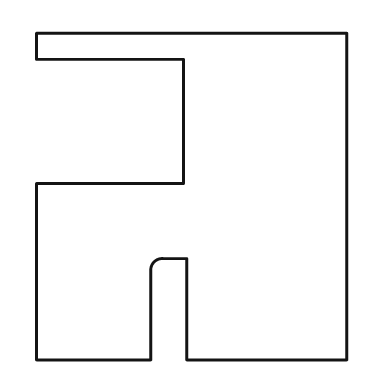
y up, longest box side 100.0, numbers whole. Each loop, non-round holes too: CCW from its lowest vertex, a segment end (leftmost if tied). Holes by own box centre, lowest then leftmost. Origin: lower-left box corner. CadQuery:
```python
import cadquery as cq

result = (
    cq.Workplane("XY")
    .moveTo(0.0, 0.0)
    .lineTo(35.0, 0.0)
    .lineTo(35.0, 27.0)
    .threePointArc((36.0, 30.0), (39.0, 31.0))
    .lineTo(46.0, 31.0)
    .lineTo(46.0, 0.0)
    .lineTo(95.0, 0.0)
    .lineTo(95.0, 100.0)
    .lineTo(0.0, 100.0)
    .lineTo(0.0, 92.0)
    .lineTo(45.0, 92.0)
    .lineTo(45.0, 54.0)
    .lineTo(0.0, 54.0)
    .close()
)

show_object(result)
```